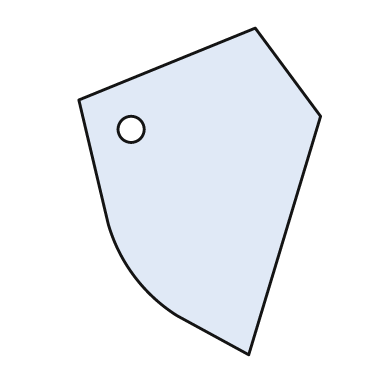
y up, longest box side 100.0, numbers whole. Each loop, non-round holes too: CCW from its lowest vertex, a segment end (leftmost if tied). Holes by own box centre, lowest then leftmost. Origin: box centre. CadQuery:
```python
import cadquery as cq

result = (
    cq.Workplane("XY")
    .moveTo(15.0, -50.0)
    .lineTo(37.0, 23.0)
    .lineTo(17.0, 50.0)
    .lineTo(-37.0, 28.0)
    .lineTo(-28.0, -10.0)
    .threePointArc((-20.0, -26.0), (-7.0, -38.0))
    .close()
    .moveTo(-21.0, 19.0)
    .circle(4.0)
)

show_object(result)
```